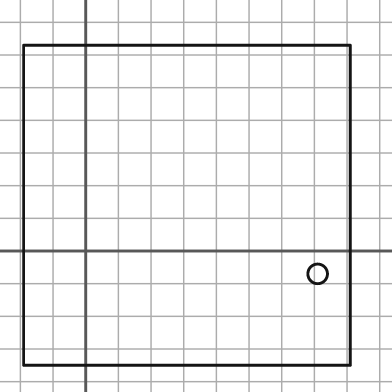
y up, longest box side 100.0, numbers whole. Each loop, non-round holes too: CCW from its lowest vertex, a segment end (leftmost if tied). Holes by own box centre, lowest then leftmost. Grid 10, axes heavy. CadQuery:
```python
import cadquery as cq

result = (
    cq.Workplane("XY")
    .moveTo(-19.0, -35.0)
    .lineTo(81.0, -35.0)
    .lineTo(81.0, 63.0)
    .lineTo(-19.0, 63.0)
    .close()
    .moveTo(71.0, -7.0)
    .circle(3.0)
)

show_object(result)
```